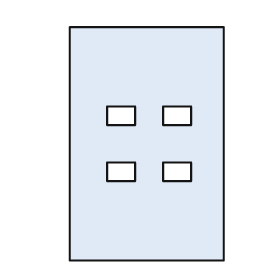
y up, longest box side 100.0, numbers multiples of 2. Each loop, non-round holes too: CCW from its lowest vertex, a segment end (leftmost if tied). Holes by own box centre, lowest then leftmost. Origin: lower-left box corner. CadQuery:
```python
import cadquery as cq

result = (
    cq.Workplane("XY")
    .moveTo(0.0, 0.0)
    .lineTo(66.0, 0.0)
    .lineTo(66.0, 100.0)
    .lineTo(0.0, 100.0)
    .close()
    .moveTo(16.0, 34.0)
    .lineTo(28.0, 34.0)
    .lineTo(28.0, 42.0)
    .lineTo(16.0, 42.0)
    .close()
    .moveTo(40.0, 34.0)
    .lineTo(52.0, 34.0)
    .lineTo(52.0, 42.0)
    .lineTo(40.0, 42.0)
    .close()
    .moveTo(16.0, 58.0)
    .lineTo(28.0, 58.0)
    .lineTo(28.0, 66.0)
    .lineTo(16.0, 66.0)
    .close()
    .moveTo(40.0, 58.0)
    .lineTo(52.0, 58.0)
    .lineTo(52.0, 66.0)
    .lineTo(40.0, 66.0)
    .close()
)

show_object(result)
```